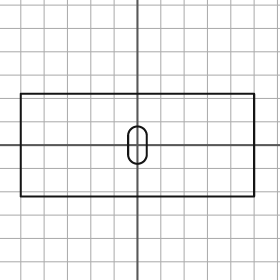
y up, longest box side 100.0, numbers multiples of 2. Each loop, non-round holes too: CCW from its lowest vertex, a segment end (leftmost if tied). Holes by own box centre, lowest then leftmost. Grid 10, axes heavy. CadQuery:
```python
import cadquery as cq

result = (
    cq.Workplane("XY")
    .moveTo(-50.0, -22.0)
    .lineTo(50.0, -22.0)
    .lineTo(50.0, 22.0)
    .lineTo(-50.0, 22.0)
    .close()
    .moveTo(-4.0, -4.0)
    .threePointArc((0.0, -8.0), (4.0, -4.0))
    .lineTo(4.0, 4.0)
    .threePointArc((0.0, 8.0), (-4.0, 4.0))
    .close()
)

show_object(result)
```